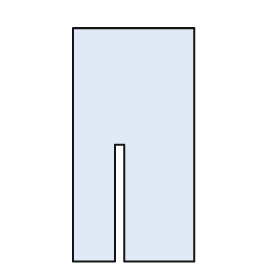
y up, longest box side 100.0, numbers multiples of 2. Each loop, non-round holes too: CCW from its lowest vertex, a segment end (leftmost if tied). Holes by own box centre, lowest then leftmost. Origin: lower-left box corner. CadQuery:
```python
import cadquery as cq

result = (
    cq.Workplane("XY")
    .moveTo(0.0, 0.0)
    .lineTo(18.0, 0.0)
    .lineTo(18.0, 50.0)
    .lineTo(22.0, 50.0)
    .lineTo(22.0, 0.0)
    .lineTo(52.0, 0.0)
    .lineTo(52.0, 100.0)
    .lineTo(0.0, 100.0)
    .close()
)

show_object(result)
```